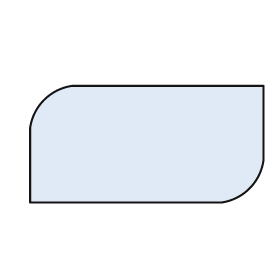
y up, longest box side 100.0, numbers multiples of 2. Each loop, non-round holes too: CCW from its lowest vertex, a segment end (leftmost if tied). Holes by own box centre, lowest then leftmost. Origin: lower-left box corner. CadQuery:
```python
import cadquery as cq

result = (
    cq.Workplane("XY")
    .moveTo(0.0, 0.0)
    .lineTo(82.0, 0.0)
    .threePointArc((94.0, 6.0), (100.0, 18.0))
    .lineTo(100.0, 50.0)
    .lineTo(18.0, 50.0)
    .threePointArc((6.0, 44.0), (0.0, 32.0))
    .close()
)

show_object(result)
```